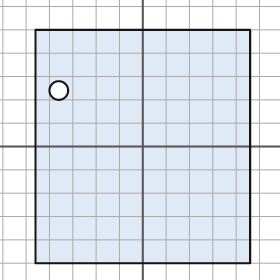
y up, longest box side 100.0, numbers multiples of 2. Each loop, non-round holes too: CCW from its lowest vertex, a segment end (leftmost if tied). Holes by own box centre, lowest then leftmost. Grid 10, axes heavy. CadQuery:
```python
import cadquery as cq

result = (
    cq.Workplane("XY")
    .moveTo(-46.0, -50.0)
    .lineTo(46.0, -50.0)
    .lineTo(46.0, 50.0)
    .lineTo(-46.0, 50.0)
    .close()
    .moveTo(-36.0, 24.0)
    .circle(4.0)
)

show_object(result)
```